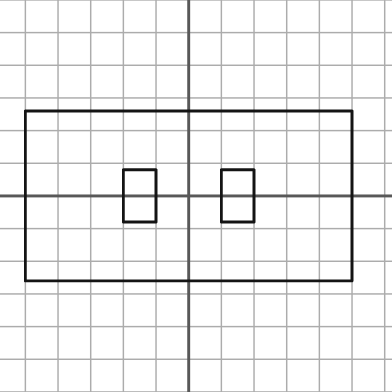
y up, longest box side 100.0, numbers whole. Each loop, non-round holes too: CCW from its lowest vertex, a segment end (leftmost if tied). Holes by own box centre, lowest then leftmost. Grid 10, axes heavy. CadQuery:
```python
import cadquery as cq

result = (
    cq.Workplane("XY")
    .moveTo(-50.0, -26.0)
    .lineTo(50.0, -26.0)
    .lineTo(50.0, 26.0)
    .lineTo(-50.0, 26.0)
    .close()
    .moveTo(-20.0, -8.0)
    .lineTo(-10.0, -8.0)
    .lineTo(-10.0, 8.0)
    .lineTo(-20.0, 8.0)
    .close()
    .moveTo(10.0, -8.0)
    .lineTo(20.0, -8.0)
    .lineTo(20.0, 8.0)
    .lineTo(10.0, 8.0)
    .close()
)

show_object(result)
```